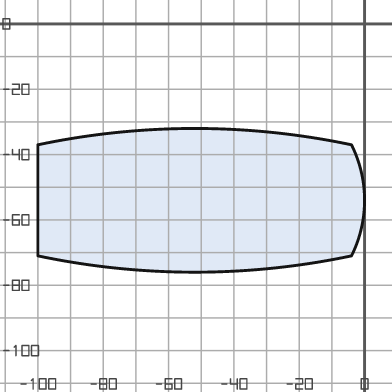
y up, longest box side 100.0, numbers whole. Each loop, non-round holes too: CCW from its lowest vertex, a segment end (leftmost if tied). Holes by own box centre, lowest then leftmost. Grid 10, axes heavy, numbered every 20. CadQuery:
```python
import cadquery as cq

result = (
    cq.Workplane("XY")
    .moveTo(-100.0, -71.0)
    .threePointArc((-52.0, -76.0), (-4.0, -71.0))
    .threePointArc((0.0, -54.0), (-4.0, -37.0))
    .threePointArc((-52.0, -32.0), (-100.0, -37.0))
    .close()
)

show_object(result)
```